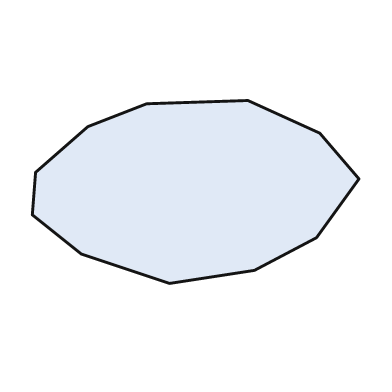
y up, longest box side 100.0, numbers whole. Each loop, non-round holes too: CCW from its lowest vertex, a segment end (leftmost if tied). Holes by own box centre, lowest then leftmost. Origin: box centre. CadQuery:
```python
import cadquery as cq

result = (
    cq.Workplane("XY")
    .moveTo(-8.0, -28.0)
    .lineTo(18.0, -24.0)
    .lineTo(37.0, -14.0)
    .lineTo(50.0, 4.0)
    .lineTo(38.0, 18.0)
    .lineTo(16.0, 28.0)
    .lineTo(-15.0, 27.0)
    .lineTo(-33.0, 20.0)
    .lineTo(-49.0, 6.0)
    .lineTo(-50.0, -7.0)
    .lineTo(-35.0, -19.0)
    .close()
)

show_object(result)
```